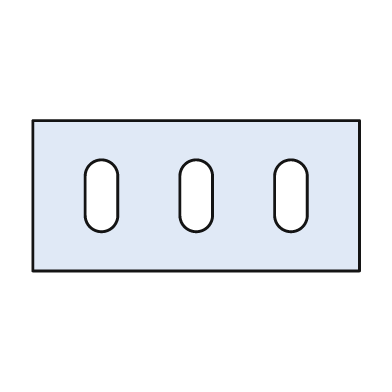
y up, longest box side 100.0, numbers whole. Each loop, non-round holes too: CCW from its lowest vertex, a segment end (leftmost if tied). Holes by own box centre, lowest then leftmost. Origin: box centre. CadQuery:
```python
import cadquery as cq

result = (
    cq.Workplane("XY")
    .moveTo(-50.0, -23.0)
    .lineTo(50.0, -23.0)
    .lineTo(50.0, 23.0)
    .lineTo(-50.0, 23.0)
    .close()
    .moveTo(-34.0, -6.0)
    .threePointArc((-29.0, -11.0), (-24.0, -6.0))
    .lineTo(-24.0, 6.0)
    .threePointArc((-29.0, 11.0), (-34.0, 6.0))
    .close()
    .moveTo(-5.0, -6.0)
    .threePointArc((0.0, -11.0), (5.0, -6.0))
    .lineTo(5.0, 6.0)
    .threePointArc((0.0, 11.0), (-5.0, 6.0))
    .close()
    .moveTo(24.0, -6.0)
    .threePointArc((29.0, -11.0), (34.0, -6.0))
    .lineTo(34.0, 6.0)
    .threePointArc((29.0, 11.0), (24.0, 6.0))
    .close()
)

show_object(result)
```